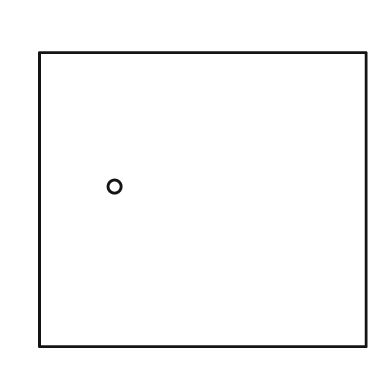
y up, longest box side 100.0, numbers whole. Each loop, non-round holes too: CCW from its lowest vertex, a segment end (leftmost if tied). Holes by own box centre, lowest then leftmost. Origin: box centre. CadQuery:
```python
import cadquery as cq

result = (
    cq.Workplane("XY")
    .moveTo(-50.0, -45.0)
    .lineTo(50.0, -45.0)
    .lineTo(50.0, 45.0)
    .lineTo(-50.0, 45.0)
    .close()
    .moveTo(-27.0, 4.0)
    .circle(2.0)
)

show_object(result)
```